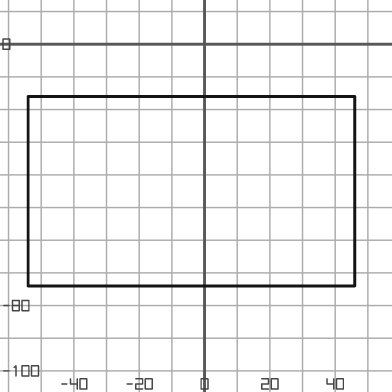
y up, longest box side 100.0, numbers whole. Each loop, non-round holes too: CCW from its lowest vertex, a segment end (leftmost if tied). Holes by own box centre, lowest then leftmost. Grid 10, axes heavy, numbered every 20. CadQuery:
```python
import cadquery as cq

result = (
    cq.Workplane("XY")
    .moveTo(-54.0, -74.0)
    .lineTo(46.0, -74.0)
    .lineTo(46.0, -16.0)
    .lineTo(-54.0, -16.0)
    .close()
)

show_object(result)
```